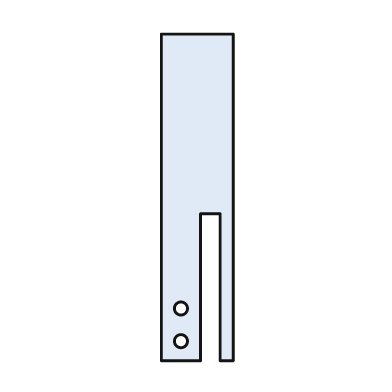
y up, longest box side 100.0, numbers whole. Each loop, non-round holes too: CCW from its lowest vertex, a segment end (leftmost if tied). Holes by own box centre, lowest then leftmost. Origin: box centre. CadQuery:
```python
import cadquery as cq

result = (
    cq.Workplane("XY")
    .moveTo(-11.0, -50.0)
    .lineTo(1.0, -50.0)
    .lineTo(1.0, -5.0)
    .lineTo(7.0, -5.0)
    .lineTo(7.0, -50.0)
    .lineTo(11.0, -50.0)
    .lineTo(11.0, 50.0)
    .lineTo(-11.0, 50.0)
    .close()
    .moveTo(-5.0, -44.0)
    .circle(2.0)
    .moveTo(-5.0, -34.0)
    .circle(2.0)
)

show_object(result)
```